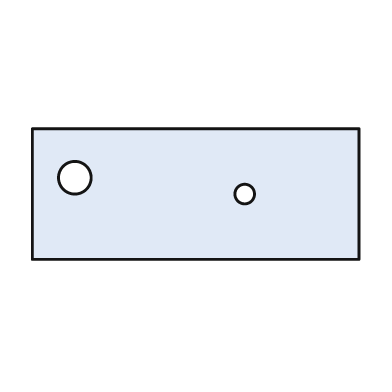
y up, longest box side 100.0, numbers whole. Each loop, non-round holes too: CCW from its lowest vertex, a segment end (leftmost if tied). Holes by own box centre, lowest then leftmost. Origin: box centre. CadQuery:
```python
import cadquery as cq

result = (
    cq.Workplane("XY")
    .moveTo(-50.0, -20.0)
    .lineTo(50.0, -20.0)
    .lineTo(50.0, 20.0)
    .lineTo(-50.0, 20.0)
    .close()
    .moveTo(15.0, 0.0)
    .circle(3.0)
    .moveTo(-37.0, 5.0)
    .circle(5.0)
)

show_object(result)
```